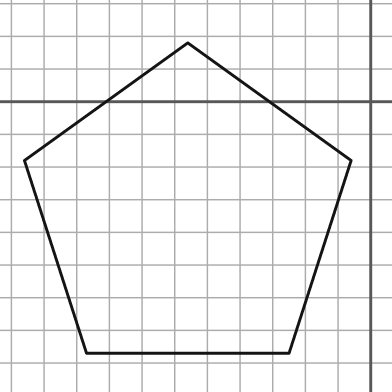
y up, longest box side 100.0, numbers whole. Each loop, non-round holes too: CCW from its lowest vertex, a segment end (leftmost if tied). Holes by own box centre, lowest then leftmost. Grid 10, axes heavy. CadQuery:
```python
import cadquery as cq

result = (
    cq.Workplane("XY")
    .moveTo(-87.0, -77.0)
    .lineTo(-25.0, -77.0)
    .lineTo(-6.0, -18.0)
    .lineTo(-56.0, 18.0)
    .lineTo(-106.0, -18.0)
    .close()
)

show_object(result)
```